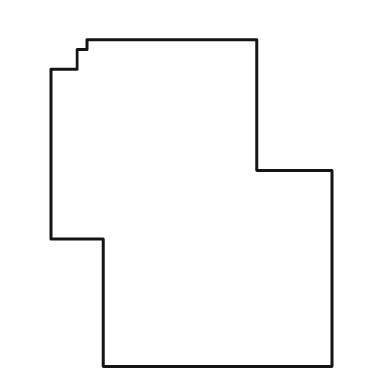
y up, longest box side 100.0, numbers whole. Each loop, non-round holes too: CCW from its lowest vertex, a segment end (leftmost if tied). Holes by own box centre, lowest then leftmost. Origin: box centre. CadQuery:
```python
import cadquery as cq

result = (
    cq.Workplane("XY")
    .moveTo(-27.0, -50.0)
    .lineTo(43.0, -50.0)
    .lineTo(43.0, 10.0)
    .lineTo(20.0, 10.0)
    .lineTo(20.0, 50.0)
    .lineTo(-32.0, 50.0)
    .lineTo(-32.0, 47.0)
    .lineTo(-35.0, 47.0)
    .lineTo(-35.0, 41.0)
    .lineTo(-43.0, 41.0)
    .lineTo(-43.0, -11.0)
    .lineTo(-27.0, -11.0)
    .close()
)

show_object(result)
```